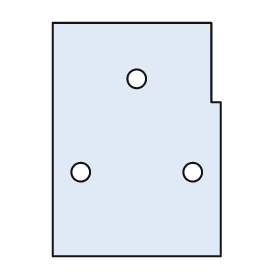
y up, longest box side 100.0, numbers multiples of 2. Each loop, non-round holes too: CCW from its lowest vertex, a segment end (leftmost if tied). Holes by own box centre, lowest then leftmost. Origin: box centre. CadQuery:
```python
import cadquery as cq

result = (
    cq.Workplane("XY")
    .moveTo(-36.0, -50.0)
    .lineTo(36.0, -50.0)
    .lineTo(36.0, 16.0)
    .lineTo(32.0, 16.0)
    .lineTo(32.0, 50.0)
    .lineTo(-36.0, 50.0)
    .close()
    .moveTo(-24.0, -14.0)
    .circle(4.0)
    .moveTo(24.0, -14.0)
    .circle(4.0)
    .moveTo(0.0, 26.0)
    .circle(4.0)
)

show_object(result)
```